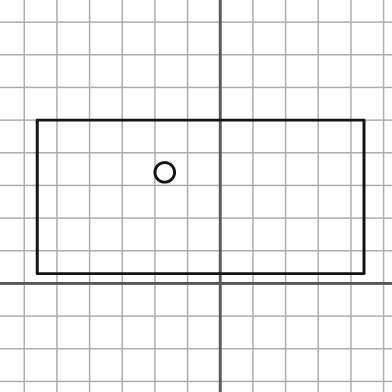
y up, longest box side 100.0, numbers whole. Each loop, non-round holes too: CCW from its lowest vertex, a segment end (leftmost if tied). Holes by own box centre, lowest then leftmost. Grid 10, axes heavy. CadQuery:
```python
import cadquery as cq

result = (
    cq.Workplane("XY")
    .moveTo(-56.0, 3.0)
    .lineTo(44.0, 3.0)
    .lineTo(44.0, 50.0)
    .lineTo(-56.0, 50.0)
    .close()
    .moveTo(-17.0, 34.0)
    .circle(3.0)
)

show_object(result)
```